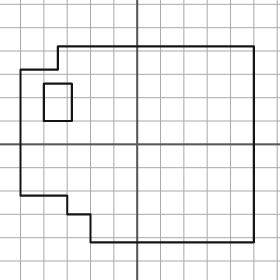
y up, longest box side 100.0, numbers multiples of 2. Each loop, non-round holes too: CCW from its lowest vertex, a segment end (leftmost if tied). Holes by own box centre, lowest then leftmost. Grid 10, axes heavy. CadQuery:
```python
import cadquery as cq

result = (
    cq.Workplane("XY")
    .moveTo(-20.0, -42.0)
    .lineTo(50.0, -42.0)
    .lineTo(50.0, 42.0)
    .lineTo(-34.0, 42.0)
    .lineTo(-34.0, 32.0)
    .lineTo(-50.0, 32.0)
    .lineTo(-50.0, -22.0)
    .lineTo(-30.0, -22.0)
    .lineTo(-30.0, -30.0)
    .lineTo(-20.0, -30.0)
    .close()
    .moveTo(-40.0, 10.0)
    .lineTo(-28.0, 10.0)
    .lineTo(-28.0, 26.0)
    .lineTo(-40.0, 26.0)
    .close()
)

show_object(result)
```